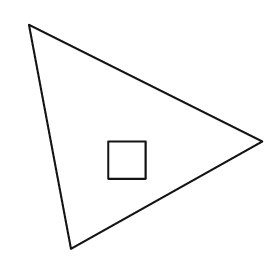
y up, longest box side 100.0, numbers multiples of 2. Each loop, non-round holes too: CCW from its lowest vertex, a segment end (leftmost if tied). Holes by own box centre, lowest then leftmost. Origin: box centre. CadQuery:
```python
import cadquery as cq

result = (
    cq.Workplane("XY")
    .moveTo(-32.0, -48.0)
    .lineTo(50.0, -2.0)
    .lineTo(-50.0, 48.0)
    .close()
    .moveTo(-16.0, -18.0)
    .lineTo(0.0, -18.0)
    .lineTo(0.0, -2.0)
    .lineTo(-16.0, -2.0)
    .close()
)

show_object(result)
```